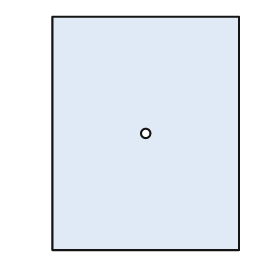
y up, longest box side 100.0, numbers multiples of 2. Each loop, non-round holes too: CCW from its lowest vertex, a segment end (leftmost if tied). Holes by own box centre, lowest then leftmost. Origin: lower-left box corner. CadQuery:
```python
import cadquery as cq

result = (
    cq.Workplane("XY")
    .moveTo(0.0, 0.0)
    .lineTo(80.0, 0.0)
    .lineTo(80.0, 100.0)
    .lineTo(0.0, 100.0)
    .close()
    .moveTo(40.0, 50.0)
    .circle(2.0)
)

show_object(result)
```